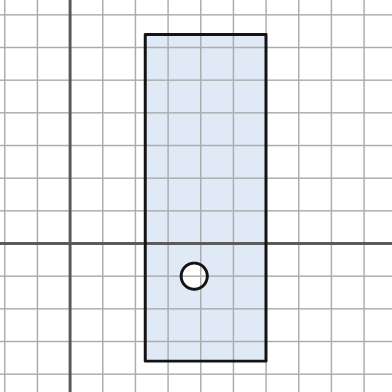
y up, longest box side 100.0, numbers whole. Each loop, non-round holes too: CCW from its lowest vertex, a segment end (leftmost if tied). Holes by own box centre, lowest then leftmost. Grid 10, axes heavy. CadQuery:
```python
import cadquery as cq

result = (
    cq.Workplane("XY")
    .moveTo(23.0, -36.0)
    .lineTo(60.0, -36.0)
    .lineTo(60.0, 64.0)
    .lineTo(23.0, 64.0)
    .close()
    .moveTo(38.0, -10.0)
    .circle(4.0)
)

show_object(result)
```